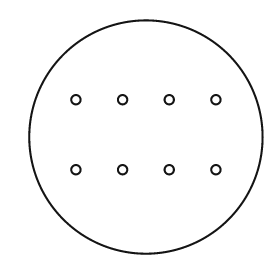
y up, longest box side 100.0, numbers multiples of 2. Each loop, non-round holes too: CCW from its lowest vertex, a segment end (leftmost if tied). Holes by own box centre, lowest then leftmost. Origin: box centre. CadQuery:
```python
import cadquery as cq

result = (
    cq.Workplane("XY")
    .moveTo(0.0, 0.0)
    .circle(50.0)
    .moveTo(-30.0, -14.0)
    .circle(2.0)
    .moveTo(-10.0, -14.0)
    .circle(2.0)
    .moveTo(10.0, -14.0)
    .circle(2.0)
    .moveTo(30.0, -14.0)
    .circle(2.0)
    .moveTo(-30.0, 16.0)
    .circle(2.0)
    .moveTo(-10.0, 16.0)
    .circle(2.0)
    .moveTo(10.0, 16.0)
    .circle(2.0)
    .moveTo(30.0, 16.0)
    .circle(2.0)
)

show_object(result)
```